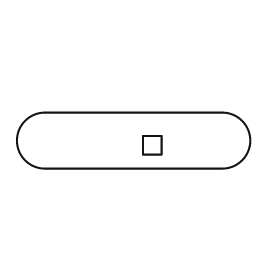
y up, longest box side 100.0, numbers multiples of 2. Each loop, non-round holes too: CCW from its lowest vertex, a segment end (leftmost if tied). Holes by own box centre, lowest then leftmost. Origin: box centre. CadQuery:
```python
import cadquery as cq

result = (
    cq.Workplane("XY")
    .moveTo(-38.0, -12.0)
    .lineTo(38.0, -12.0)
    .threePointArc((50.0, 0.0), (38.0, 12.0))
    .lineTo(-38.0, 12.0)
    .threePointArc((-50.0, 0.0), (-38.0, -12.0))
    .close()
    .moveTo(4.0, -6.0)
    .lineTo(12.0, -6.0)
    .lineTo(12.0, 2.0)
    .lineTo(4.0, 2.0)
    .close()
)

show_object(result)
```